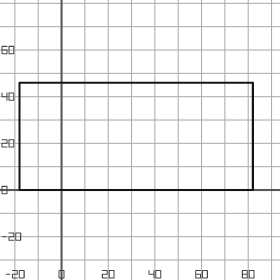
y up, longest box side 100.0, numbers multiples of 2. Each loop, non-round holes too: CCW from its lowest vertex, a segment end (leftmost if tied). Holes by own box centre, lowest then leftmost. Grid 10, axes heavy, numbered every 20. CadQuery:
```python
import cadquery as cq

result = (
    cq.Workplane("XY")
    .moveTo(-18.0, 0.0)
    .lineTo(82.0, 0.0)
    .lineTo(82.0, 46.0)
    .lineTo(-18.0, 46.0)
    .close()
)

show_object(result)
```